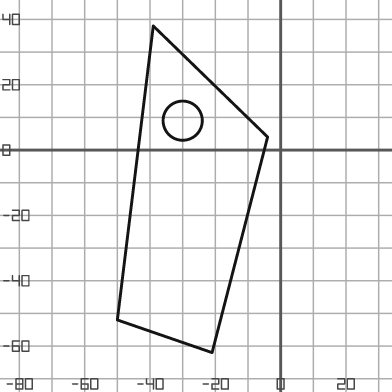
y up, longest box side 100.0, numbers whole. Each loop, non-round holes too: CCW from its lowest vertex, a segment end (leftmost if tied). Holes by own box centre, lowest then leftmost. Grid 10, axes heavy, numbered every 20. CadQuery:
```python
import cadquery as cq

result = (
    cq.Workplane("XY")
    .moveTo(-21.0, -62.0)
    .lineTo(-4.0, 4.0)
    .lineTo(-39.0, 38.0)
    .lineTo(-50.0, -52.0)
    .close()
    .moveTo(-30.0, 9.0)
    .circle(6.0)
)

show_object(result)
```